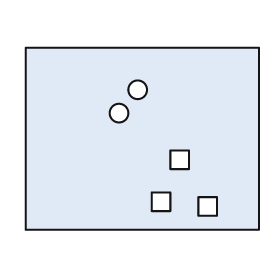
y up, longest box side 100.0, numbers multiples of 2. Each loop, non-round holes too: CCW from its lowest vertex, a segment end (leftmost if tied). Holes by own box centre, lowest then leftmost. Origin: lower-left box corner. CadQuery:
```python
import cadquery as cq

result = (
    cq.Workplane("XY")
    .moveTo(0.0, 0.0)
    .lineTo(100.0, 0.0)
    .lineTo(100.0, 78.0)
    .lineTo(0.0, 78.0)
    .close()
    .moveTo(74.0, 6.0)
    .lineTo(82.0, 6.0)
    .lineTo(82.0, 14.0)
    .lineTo(74.0, 14.0)
    .close()
    .moveTo(54.0, 8.0)
    .lineTo(62.0, 8.0)
    .lineTo(62.0, 16.0)
    .lineTo(54.0, 16.0)
    .close()
    .moveTo(62.0, 26.0)
    .lineTo(70.0, 26.0)
    .lineTo(70.0, 34.0)
    .lineTo(62.0, 34.0)
    .close()
    .moveTo(40.0, 50.0)
    .circle(4.0)
    .moveTo(48.0, 60.0)
    .circle(4.0)
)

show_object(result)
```